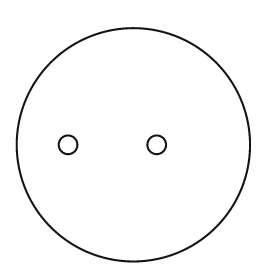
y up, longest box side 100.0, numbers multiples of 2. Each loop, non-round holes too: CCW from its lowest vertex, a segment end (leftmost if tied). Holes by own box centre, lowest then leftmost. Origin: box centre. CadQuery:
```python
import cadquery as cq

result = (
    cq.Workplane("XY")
    .moveTo(0.0, 0.0)
    .circle(50.0)
    .moveTo(-28.0, 0.0)
    .circle(4.0)
    .moveTo(10.0, 0.0)
    .circle(4.0)
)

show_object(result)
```